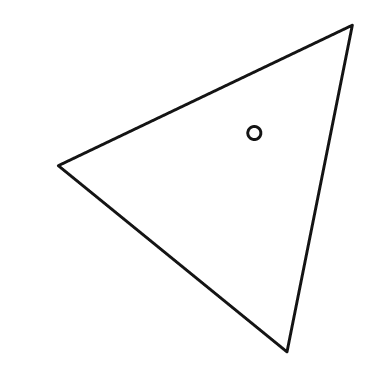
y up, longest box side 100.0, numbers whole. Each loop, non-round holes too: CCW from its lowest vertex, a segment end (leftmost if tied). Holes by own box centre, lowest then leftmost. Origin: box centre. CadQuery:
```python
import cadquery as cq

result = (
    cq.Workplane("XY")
    .moveTo(25.0, -50.0)
    .lineTo(45.0, 50.0)
    .lineTo(-45.0, 7.0)
    .close()
    .moveTo(15.0, 17.0)
    .circle(2.0)
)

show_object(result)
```